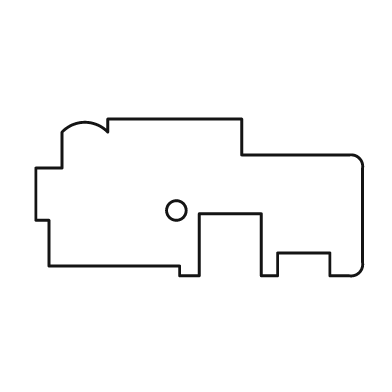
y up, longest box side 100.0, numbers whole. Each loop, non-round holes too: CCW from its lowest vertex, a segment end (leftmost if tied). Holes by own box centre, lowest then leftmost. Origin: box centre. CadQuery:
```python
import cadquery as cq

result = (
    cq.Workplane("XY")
    .moveTo(-6.0, -24.0)
    .lineTo(0.0, -24.0)
    .lineTo(0.0, -5.0)
    .lineTo(19.0, -5.0)
    .lineTo(19.0, -24.0)
    .lineTo(24.0, -24.0)
    .lineTo(24.0, -17.0)
    .lineTo(40.0, -17.0)
    .lineTo(40.0, -24.0)
    .lineTo(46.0, -24.0)
    .threePointArc((49.0, -23.0), (50.0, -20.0))
    .lineTo(50.0, 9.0)
    .threePointArc((49.0, 12.0), (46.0, 13.0))
    .lineTo(13.0, 13.0)
    .lineTo(13.0, 24.0)
    .lineTo(-28.0, 24.0)
    .lineTo(-28.0, 20.0)
    .threePointArc((-35.0, 23.0), (-42.0, 20.0))
    .lineTo(-42.0, 9.0)
    .lineTo(-50.0, 9.0)
    .lineTo(-50.0, -7.0)
    .lineTo(-46.0, -7.0)
    .lineTo(-46.0, -21.0)
    .lineTo(-6.0, -21.0)
    .close()
    .moveTo(-7.0, -4.0)
    .circle(3.0)
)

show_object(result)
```